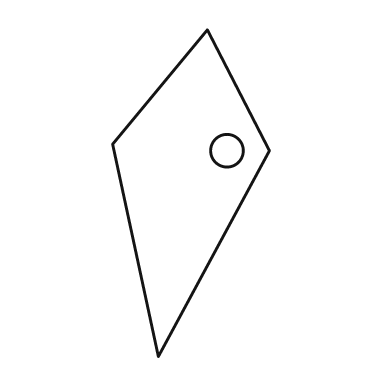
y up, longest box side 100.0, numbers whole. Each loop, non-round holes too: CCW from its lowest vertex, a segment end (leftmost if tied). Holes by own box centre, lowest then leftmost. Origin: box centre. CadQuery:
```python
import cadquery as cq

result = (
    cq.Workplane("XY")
    .moveTo(-10.0, -50.0)
    .lineTo(24.0, 13.0)
    .lineTo(5.0, 50.0)
    .lineTo(-24.0, 15.0)
    .close()
    .moveTo(11.0, 13.0)
    .circle(5.0)
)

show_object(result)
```